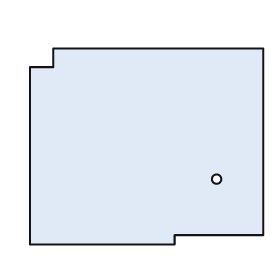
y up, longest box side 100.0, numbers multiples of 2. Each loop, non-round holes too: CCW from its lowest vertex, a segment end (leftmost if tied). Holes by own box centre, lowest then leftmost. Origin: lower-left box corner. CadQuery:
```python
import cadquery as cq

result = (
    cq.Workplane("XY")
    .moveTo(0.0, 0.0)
    .lineTo(62.0, 0.0)
    .lineTo(62.0, 4.0)
    .lineTo(100.0, 4.0)
    .lineTo(100.0, 84.0)
    .lineTo(10.0, 84.0)
    .lineTo(10.0, 76.0)
    .lineTo(0.0, 76.0)
    .close()
    .moveTo(80.0, 28.0)
    .circle(2.0)
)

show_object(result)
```